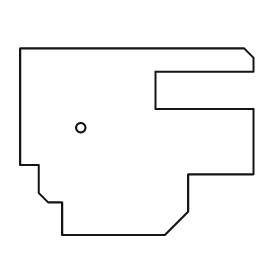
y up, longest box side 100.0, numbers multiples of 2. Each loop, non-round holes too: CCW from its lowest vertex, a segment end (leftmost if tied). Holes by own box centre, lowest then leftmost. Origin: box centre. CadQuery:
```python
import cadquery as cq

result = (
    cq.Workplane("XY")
    .moveTo(-32.0, -40.0)
    .lineTo(12.0, -40.0)
    .lineTo(22.0, -30.0)
    .lineTo(22.0, -14.0)
    .lineTo(50.0, -14.0)
    .lineTo(50.0, 14.0)
    .lineTo(8.0, 14.0)
    .lineTo(8.0, 30.0)
    .lineTo(50.0, 30.0)
    .lineTo(50.0, 36.0)
    .lineTo(46.0, 40.0)
    .lineTo(-50.0, 40.0)
    .lineTo(-50.0, -10.0)
    .lineTo(-42.0, -10.0)
    .lineTo(-42.0, -22.0)
    .lineTo(-38.0, -26.0)
    .lineTo(-32.0, -26.0)
    .close()
    .moveTo(-24.0, 6.0)
    .circle(2.0)
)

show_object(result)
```